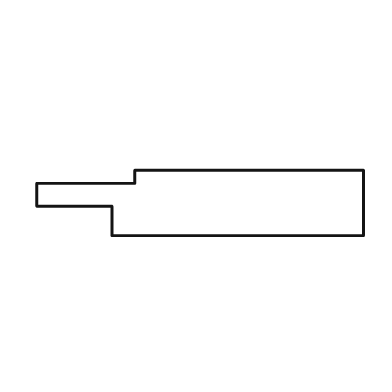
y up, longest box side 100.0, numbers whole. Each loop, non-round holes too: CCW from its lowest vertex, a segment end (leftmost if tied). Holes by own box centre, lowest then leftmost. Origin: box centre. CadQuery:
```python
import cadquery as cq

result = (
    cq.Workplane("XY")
    .moveTo(-27.0, -10.0)
    .lineTo(50.0, -10.0)
    .lineTo(50.0, 10.0)
    .lineTo(-20.0, 10.0)
    .lineTo(-20.0, 6.0)
    .lineTo(-50.0, 6.0)
    .lineTo(-50.0, -1.0)
    .lineTo(-27.0, -1.0)
    .close()
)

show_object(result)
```